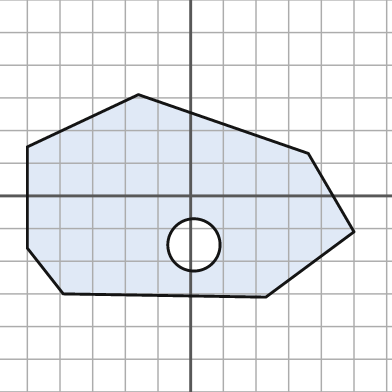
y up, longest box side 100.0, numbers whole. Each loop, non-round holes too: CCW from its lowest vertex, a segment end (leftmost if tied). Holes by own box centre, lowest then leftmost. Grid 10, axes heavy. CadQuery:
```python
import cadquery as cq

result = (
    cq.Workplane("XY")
    .moveTo(23.0, -31.0)
    .lineTo(50.0, -11.0)
    .lineTo(36.0, 13.0)
    .lineTo(-16.0, 31.0)
    .lineTo(-50.0, 15.0)
    .lineTo(-50.0, -16.0)
    .lineTo(-39.0, -30.0)
    .close()
    .moveTo(1.0, -15.0)
    .circle(8.0)
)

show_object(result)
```